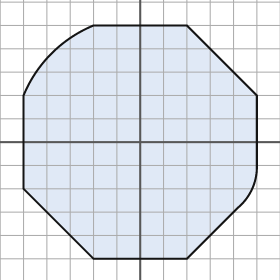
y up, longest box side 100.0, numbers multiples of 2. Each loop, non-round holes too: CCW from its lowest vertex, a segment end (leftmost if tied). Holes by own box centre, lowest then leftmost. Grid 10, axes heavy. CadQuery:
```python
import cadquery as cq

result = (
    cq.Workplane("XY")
    .moveTo(-20.0, -50.0)
    .lineTo(20.0, -50.0)
    .lineTo(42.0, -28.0)
    .threePointArc((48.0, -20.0), (50.0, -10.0))
    .lineTo(50.0, 20.0)
    .lineTo(20.0, 50.0)
    .lineTo(-20.0, 50.0)
    .threePointArc((-38.0, 38.0), (-50.0, 20.0))
    .lineTo(-50.0, -20.0)
    .close()
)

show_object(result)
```